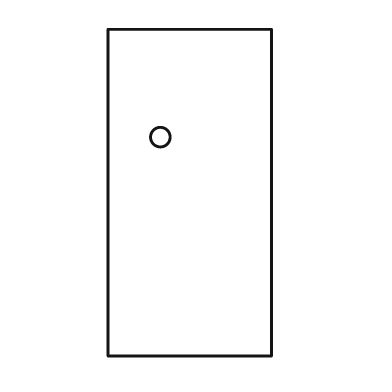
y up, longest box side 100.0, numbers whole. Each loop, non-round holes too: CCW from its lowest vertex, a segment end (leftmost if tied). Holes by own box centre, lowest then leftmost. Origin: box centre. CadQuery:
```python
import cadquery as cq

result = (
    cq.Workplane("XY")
    .moveTo(-25.0, -50.0)
    .lineTo(25.0, -50.0)
    .lineTo(25.0, 50.0)
    .lineTo(-25.0, 50.0)
    .close()
    .moveTo(-9.0, 17.0)
    .circle(3.0)
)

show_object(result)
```